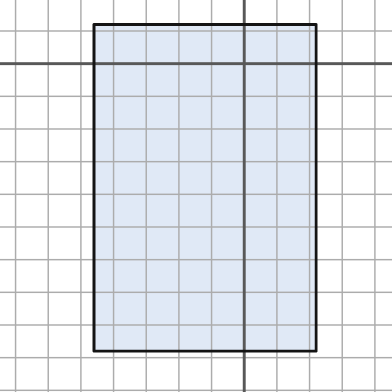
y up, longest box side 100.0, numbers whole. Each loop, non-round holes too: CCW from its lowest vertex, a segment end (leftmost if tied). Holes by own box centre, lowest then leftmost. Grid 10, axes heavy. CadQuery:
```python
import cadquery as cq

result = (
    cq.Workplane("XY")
    .moveTo(-46.0, -88.0)
    .lineTo(22.0, -88.0)
    .lineTo(22.0, 12.0)
    .lineTo(-46.0, 12.0)
    .close()
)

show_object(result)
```